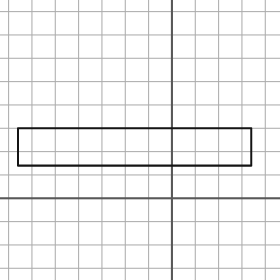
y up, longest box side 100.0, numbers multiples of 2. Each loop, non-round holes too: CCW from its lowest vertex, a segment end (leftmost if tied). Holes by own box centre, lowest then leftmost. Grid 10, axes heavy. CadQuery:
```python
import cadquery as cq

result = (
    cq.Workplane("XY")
    .moveTo(-66.0, 14.0)
    .lineTo(34.0, 14.0)
    .lineTo(34.0, 30.0)
    .lineTo(-66.0, 30.0)
    .close()
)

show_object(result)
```